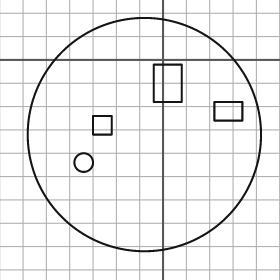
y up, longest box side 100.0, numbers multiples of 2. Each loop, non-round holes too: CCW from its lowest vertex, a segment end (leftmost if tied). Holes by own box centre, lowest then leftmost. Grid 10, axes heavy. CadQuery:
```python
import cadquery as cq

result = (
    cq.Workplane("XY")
    .moveTo(-8.0, -32.0)
    .circle(50.0)
    .moveTo(-34.0, -44.0)
    .circle(4.0)
    .moveTo(-30.0, -32.0)
    .lineTo(-22.0, -32.0)
    .lineTo(-22.0, -24.0)
    .lineTo(-30.0, -24.0)
    .close()
    .moveTo(22.0, -26.0)
    .lineTo(34.0, -26.0)
    .lineTo(34.0, -18.0)
    .lineTo(22.0, -18.0)
    .close()
    .moveTo(-4.0, -18.0)
    .lineTo(8.0, -18.0)
    .lineTo(8.0, -2.0)
    .lineTo(-4.0, -2.0)
    .close()
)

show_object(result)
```